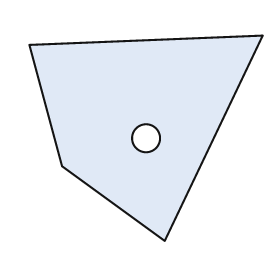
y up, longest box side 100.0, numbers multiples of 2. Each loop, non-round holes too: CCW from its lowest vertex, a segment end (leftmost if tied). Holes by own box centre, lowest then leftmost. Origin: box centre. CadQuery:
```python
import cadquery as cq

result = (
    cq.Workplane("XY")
    .moveTo(8.0, -44.0)
    .lineTo(50.0, 44.0)
    .lineTo(-50.0, 40.0)
    .lineTo(-36.0, -12.0)
    .close()
    .moveTo(0.0, 0.0)
    .circle(6.0)
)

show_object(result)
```